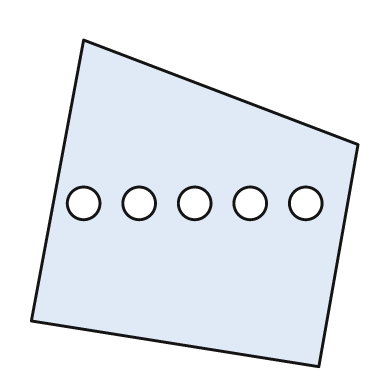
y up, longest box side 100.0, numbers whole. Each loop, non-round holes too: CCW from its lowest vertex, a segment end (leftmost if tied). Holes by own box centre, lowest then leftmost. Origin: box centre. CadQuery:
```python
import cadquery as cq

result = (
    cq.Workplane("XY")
    .moveTo(38.0, -50.0)
    .lineTo(50.0, 18.0)
    .lineTo(-34.0, 50.0)
    .lineTo(-50.0, -36.0)
    .close()
    .moveTo(-34.0, 0.0)
    .circle(5.0)
    .moveTo(-17.0, 0.0)
    .circle(5.0)
    .moveTo(0.0, 0.0)
    .circle(5.0)
    .moveTo(17.0, 0.0)
    .circle(5.0)
    .moveTo(34.0, 0.0)
    .circle(5.0)
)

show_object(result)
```